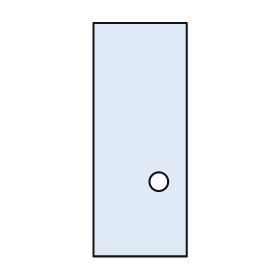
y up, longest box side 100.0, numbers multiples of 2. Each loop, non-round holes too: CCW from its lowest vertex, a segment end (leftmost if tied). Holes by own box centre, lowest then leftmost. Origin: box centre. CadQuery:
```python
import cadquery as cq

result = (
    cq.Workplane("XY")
    .moveTo(-20.0, -50.0)
    .lineTo(20.0, -50.0)
    .lineTo(20.0, 50.0)
    .lineTo(-20.0, 50.0)
    .close()
    .moveTo(8.0, -18.0)
    .circle(4.0)
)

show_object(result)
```